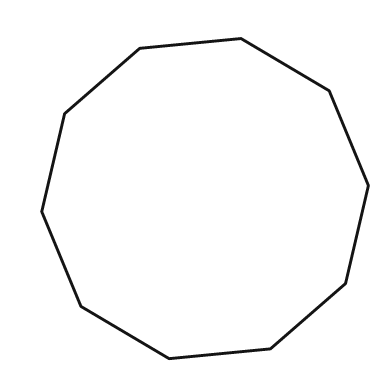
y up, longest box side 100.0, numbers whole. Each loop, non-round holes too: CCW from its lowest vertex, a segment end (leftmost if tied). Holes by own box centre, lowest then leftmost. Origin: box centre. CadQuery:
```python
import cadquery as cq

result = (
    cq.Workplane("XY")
    .moveTo(-11.0, -49.0)
    .lineTo(20.0, -46.0)
    .lineTo(43.0, -26.0)
    .lineTo(50.0, 4.0)
    .lineTo(38.0, 33.0)
    .lineTo(11.0, 49.0)
    .lineTo(-20.0, 46.0)
    .lineTo(-43.0, 26.0)
    .lineTo(-50.0, -4.0)
    .lineTo(-38.0, -33.0)
    .close()
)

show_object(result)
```